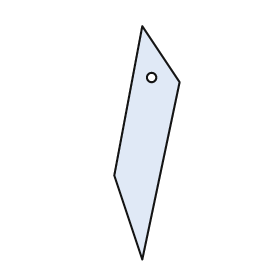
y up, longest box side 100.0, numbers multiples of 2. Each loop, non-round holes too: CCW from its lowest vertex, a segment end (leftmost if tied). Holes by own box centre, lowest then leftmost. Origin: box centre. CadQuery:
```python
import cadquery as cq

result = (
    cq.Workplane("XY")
    .moveTo(-2.0, -50.0)
    .lineTo(14.0, 26.0)
    .lineTo(-2.0, 50.0)
    .lineTo(-14.0, -14.0)
    .close()
    .moveTo(2.0, 28.0)
    .circle(2.0)
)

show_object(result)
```